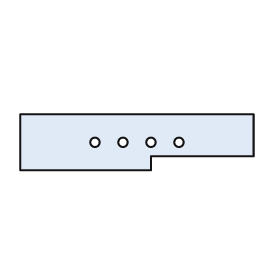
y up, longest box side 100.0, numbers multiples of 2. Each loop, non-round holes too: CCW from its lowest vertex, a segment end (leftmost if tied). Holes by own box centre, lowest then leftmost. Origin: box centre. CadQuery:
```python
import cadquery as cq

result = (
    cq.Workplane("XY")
    .moveTo(-50.0, -12.0)
    .lineTo(6.0, -12.0)
    .lineTo(6.0, -6.0)
    .lineTo(50.0, -6.0)
    .lineTo(50.0, 12.0)
    .lineTo(-50.0, 12.0)
    .close()
    .moveTo(-18.0, 0.0)
    .circle(2.0)
    .moveTo(-6.0, 0.0)
    .circle(2.0)
    .moveTo(6.0, 0.0)
    .circle(2.0)
    .moveTo(18.0, 0.0)
    .circle(2.0)
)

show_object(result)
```